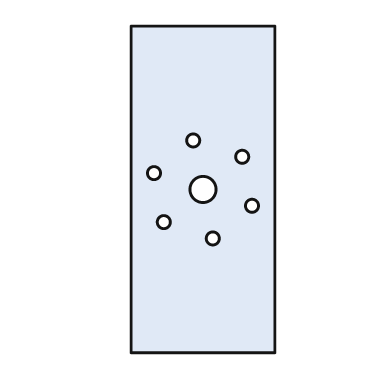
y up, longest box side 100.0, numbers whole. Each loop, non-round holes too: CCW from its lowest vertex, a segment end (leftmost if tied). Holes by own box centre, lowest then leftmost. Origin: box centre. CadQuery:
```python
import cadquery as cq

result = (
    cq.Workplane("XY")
    .moveTo(-22.0, -50.0)
    .lineTo(22.0, -50.0)
    .lineTo(22.0, 50.0)
    .lineTo(-22.0, 50.0)
    .close()
    .moveTo(3.0, -15.0)
    .circle(2.0)
    .moveTo(-12.0, -10.0)
    .circle(2.0)
    .moveTo(15.0, -5.0)
    .circle(2.0)
    .moveTo(0.0, 0.0)
    .circle(4.0)
    .moveTo(-15.0, 5.0)
    .circle(2.0)
    .moveTo(12.0, 10.0)
    .circle(2.0)
    .moveTo(-3.0, 15.0)
    .circle(2.0)
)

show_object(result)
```